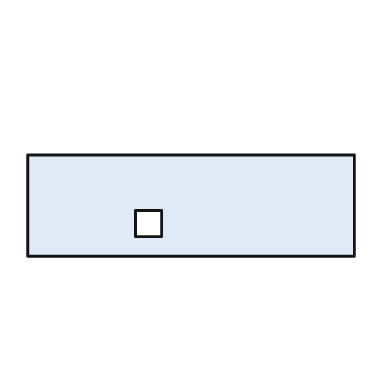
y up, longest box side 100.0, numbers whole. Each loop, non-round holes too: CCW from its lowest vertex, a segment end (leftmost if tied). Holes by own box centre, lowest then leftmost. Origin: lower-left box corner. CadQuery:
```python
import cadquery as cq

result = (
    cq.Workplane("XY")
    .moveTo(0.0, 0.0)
    .lineTo(100.0, 0.0)
    .lineTo(100.0, 31.0)
    .lineTo(0.0, 31.0)
    .close()
    .moveTo(33.0, 6.0)
    .lineTo(41.0, 6.0)
    .lineTo(41.0, 14.0)
    .lineTo(33.0, 14.0)
    .close()
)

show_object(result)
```